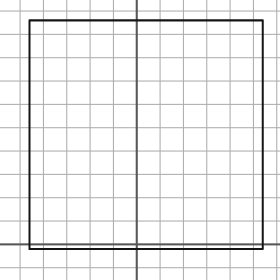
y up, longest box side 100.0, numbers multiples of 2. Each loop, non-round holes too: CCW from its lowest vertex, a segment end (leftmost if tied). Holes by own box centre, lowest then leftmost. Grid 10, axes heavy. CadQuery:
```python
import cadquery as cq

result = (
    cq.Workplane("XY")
    .moveTo(-46.0, -2.0)
    .lineTo(54.0, -2.0)
    .lineTo(54.0, 96.0)
    .lineTo(-46.0, 96.0)
    .close()
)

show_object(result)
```